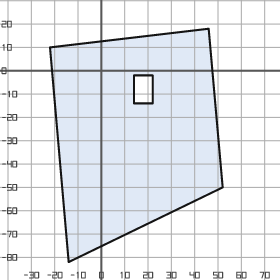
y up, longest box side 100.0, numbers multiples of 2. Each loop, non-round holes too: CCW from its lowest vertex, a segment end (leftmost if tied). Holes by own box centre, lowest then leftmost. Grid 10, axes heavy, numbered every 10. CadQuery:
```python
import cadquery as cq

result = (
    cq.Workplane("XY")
    .moveTo(-14.0, -82.0)
    .lineTo(52.0, -50.0)
    .lineTo(46.0, 18.0)
    .lineTo(-22.0, 10.0)
    .close()
    .moveTo(14.0, -14.0)
    .lineTo(22.0, -14.0)
    .lineTo(22.0, -2.0)
    .lineTo(14.0, -2.0)
    .close()
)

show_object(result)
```